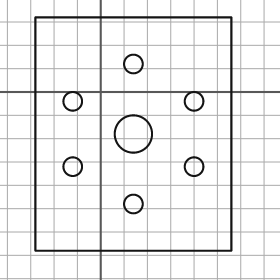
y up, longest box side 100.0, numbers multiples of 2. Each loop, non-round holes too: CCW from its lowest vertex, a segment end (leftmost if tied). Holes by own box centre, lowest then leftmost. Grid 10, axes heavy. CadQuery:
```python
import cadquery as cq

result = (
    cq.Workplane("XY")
    .moveTo(-28.0, -68.0)
    .lineTo(56.0, -68.0)
    .lineTo(56.0, 32.0)
    .lineTo(-28.0, 32.0)
    .close()
    .moveTo(14.0, -48.0)
    .circle(4.0)
    .moveTo(-12.0, -32.0)
    .circle(4.0)
    .moveTo(40.0, -32.0)
    .circle(4.0)
    .moveTo(14.0, -18.0)
    .circle(8.0)
    .moveTo(-12.0, -4.0)
    .circle(4.0)
    .moveTo(40.0, -4.0)
    .circle(4.0)
    .moveTo(14.0, 12.0)
    .circle(4.0)
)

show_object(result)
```